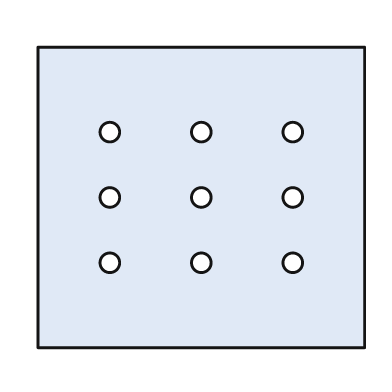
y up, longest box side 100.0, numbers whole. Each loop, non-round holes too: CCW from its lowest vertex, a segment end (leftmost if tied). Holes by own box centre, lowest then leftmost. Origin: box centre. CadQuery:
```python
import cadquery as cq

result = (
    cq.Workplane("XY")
    .moveTo(-50.0, -46.0)
    .lineTo(50.0, -46.0)
    .lineTo(50.0, 46.0)
    .lineTo(-50.0, 46.0)
    .close()
    .moveTo(-28.0, -20.0)
    .circle(3.0)
    .moveTo(0.0, -20.0)
    .circle(3.0)
    .moveTo(28.0, -20.0)
    .circle(3.0)
    .moveTo(-28.0, 0.0)
    .circle(3.0)
    .moveTo(0.0, 0.0)
    .circle(3.0)
    .moveTo(28.0, 0.0)
    .circle(3.0)
    .moveTo(-28.0, 20.0)
    .circle(3.0)
    .moveTo(0.0, 20.0)
    .circle(3.0)
    .moveTo(28.0, 20.0)
    .circle(3.0)
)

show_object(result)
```